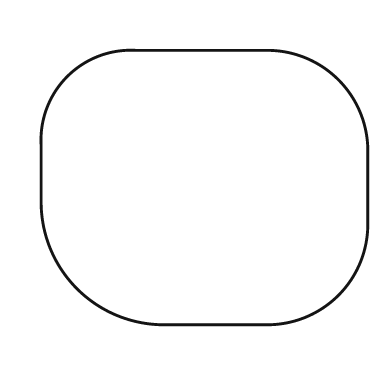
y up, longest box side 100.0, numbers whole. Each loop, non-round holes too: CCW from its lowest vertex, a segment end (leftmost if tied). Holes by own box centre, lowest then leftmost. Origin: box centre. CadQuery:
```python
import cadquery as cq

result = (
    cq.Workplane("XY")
    .moveTo(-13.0, -42.0)
    .lineTo(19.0, -42.0)
    .threePointArc((41.0, -33.0), (50.0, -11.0))
    .lineTo(50.0, 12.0)
    .threePointArc((41.0, 33.0), (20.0, 42.0))
    .lineTo(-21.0, 42.0)
    .threePointArc((-42.0, 34.0), (-50.0, 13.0))
    .lineTo(-50.0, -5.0)
    .threePointArc((-39.0, -31.0), (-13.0, -42.0))
    .close()
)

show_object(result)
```